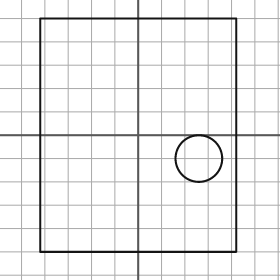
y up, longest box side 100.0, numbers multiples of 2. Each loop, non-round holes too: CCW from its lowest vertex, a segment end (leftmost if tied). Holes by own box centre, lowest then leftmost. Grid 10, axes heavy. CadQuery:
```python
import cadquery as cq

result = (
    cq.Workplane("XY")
    .moveTo(-42.0, -50.0)
    .lineTo(42.0, -50.0)
    .lineTo(42.0, 50.0)
    .lineTo(-42.0, 50.0)
    .close()
    .moveTo(26.0, -10.0)
    .circle(10.0)
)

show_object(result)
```